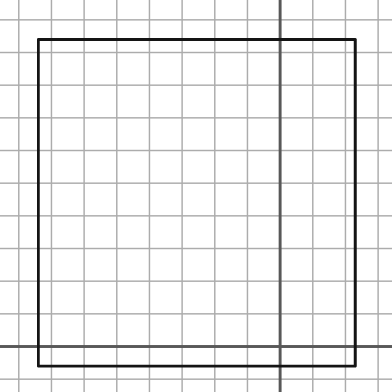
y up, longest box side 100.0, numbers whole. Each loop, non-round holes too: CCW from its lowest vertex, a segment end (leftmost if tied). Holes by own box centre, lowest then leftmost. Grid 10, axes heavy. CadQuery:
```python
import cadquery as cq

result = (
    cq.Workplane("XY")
    .moveTo(-74.0, -6.0)
    .lineTo(23.0, -6.0)
    .lineTo(23.0, 94.0)
    .lineTo(-74.0, 94.0)
    .close()
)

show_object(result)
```